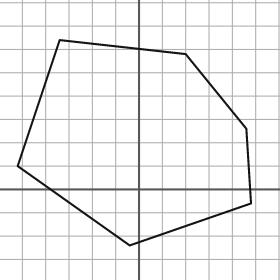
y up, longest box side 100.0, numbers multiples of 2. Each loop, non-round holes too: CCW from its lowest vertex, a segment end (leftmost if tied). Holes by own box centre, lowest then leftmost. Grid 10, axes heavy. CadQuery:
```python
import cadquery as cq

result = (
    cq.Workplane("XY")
    .moveTo(-4.0, -24.0)
    .lineTo(48.0, -6.0)
    .lineTo(46.0, 26.0)
    .lineTo(20.0, 58.0)
    .lineTo(-34.0, 64.0)
    .lineTo(-52.0, 10.0)
    .close()
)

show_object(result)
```